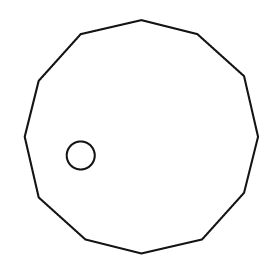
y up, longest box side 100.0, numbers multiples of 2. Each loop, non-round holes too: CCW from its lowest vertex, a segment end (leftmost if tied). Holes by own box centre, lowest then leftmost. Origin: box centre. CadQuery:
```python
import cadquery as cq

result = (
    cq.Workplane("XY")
    .moveTo(0.0, -50.0)
    .lineTo(26.0, -44.0)
    .lineTo(44.0, -24.0)
    .lineTo(50.0, 0.0)
    .lineTo(44.0, 26.0)
    .lineTo(24.0, 44.0)
    .lineTo(0.0, 50.0)
    .lineTo(-26.0, 44.0)
    .lineTo(-44.0, 24.0)
    .lineTo(-50.0, 0.0)
    .lineTo(-44.0, -26.0)
    .lineTo(-24.0, -44.0)
    .close()
    .moveTo(-26.0, -8.0)
    .circle(6.0)
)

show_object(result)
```